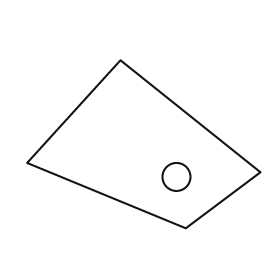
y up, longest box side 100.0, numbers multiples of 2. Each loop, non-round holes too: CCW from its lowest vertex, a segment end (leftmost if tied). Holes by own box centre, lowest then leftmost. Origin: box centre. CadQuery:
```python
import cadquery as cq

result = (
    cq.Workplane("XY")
    .moveTo(18.0, -36.0)
    .lineTo(50.0, -12.0)
    .lineTo(-10.0, 36.0)
    .lineTo(-50.0, -8.0)
    .close()
    .moveTo(14.0, -14.0)
    .circle(6.0)
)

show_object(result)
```